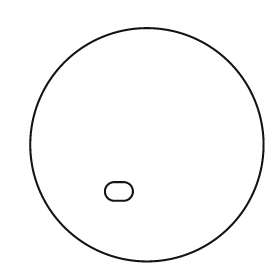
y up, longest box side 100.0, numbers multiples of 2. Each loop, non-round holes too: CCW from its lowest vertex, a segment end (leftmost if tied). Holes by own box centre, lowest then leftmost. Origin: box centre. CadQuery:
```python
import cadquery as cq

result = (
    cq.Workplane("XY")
    .moveTo(0.0, 0.0)
    .circle(50.0)
    .moveTo(-14.0, -24.0)
    .lineTo(-10.0, -24.0)
    .threePointArc((-6.0, -20.0), (-10.0, -16.0))
    .lineTo(-14.0, -16.0)
    .threePointArc((-18.0, -20.0), (-14.0, -24.0))
    .close()
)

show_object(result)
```